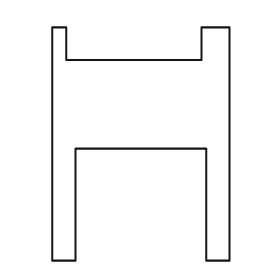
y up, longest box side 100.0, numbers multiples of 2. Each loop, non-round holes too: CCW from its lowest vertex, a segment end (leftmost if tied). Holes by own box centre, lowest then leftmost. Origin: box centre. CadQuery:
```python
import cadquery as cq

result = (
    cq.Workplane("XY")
    .moveTo(-38.0, -50.0)
    .lineTo(-28.0, -50.0)
    .lineTo(-28.0, -2.0)
    .lineTo(28.0, -2.0)
    .lineTo(28.0, -50.0)
    .lineTo(38.0, -50.0)
    .lineTo(38.0, 50.0)
    .lineTo(26.0, 50.0)
    .lineTo(26.0, 36.0)
    .lineTo(-32.0, 36.0)
    .lineTo(-32.0, 50.0)
    .lineTo(-38.0, 50.0)
    .close()
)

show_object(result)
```